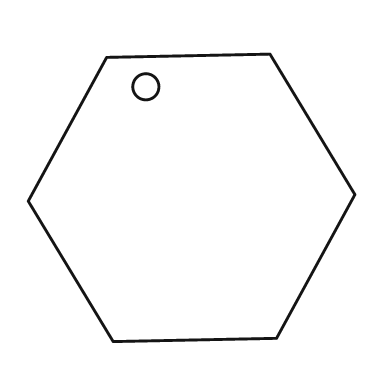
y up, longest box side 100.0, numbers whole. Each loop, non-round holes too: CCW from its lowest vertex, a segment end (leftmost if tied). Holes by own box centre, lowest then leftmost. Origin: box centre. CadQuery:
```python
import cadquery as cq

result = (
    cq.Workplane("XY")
    .moveTo(-24.0, -44.0)
    .lineTo(26.0, -43.0)
    .lineTo(50.0, 1.0)
    .lineTo(24.0, 44.0)
    .lineTo(-26.0, 43.0)
    .lineTo(-50.0, -1.0)
    .close()
    .moveTo(-14.0, 34.0)
    .circle(4.0)
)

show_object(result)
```